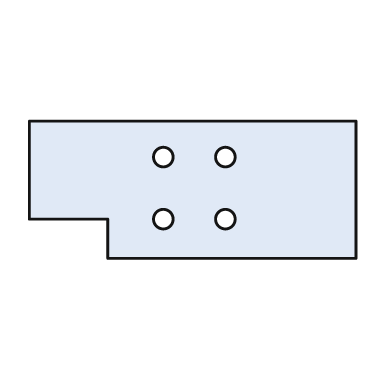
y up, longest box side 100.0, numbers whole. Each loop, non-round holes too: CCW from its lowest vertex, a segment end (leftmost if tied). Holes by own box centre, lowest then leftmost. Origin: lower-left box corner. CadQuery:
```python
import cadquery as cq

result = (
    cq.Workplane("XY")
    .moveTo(24.0, 0.0)
    .lineTo(100.0, 0.0)
    .lineTo(100.0, 42.0)
    .lineTo(0.0, 42.0)
    .lineTo(0.0, 12.0)
    .lineTo(24.0, 12.0)
    .close()
    .moveTo(41.0, 12.0)
    .circle(3.0)
    .moveTo(60.0, 12.0)
    .circle(3.0)
    .moveTo(41.0, 31.0)
    .circle(3.0)
    .moveTo(60.0, 31.0)
    .circle(3.0)
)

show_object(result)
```